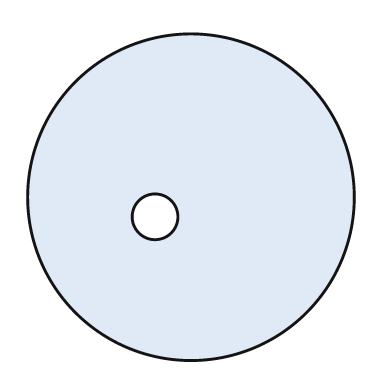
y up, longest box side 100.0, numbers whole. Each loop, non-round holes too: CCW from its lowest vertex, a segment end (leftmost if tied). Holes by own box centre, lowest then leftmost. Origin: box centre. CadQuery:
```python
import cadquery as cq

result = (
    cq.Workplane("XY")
    .moveTo(0.0, 0.0)
    .circle(50.0)
    .moveTo(-11.0, -6.0)
    .circle(7.0)
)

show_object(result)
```